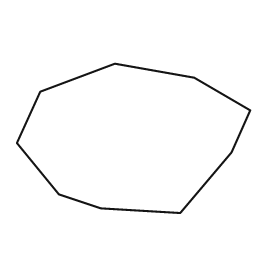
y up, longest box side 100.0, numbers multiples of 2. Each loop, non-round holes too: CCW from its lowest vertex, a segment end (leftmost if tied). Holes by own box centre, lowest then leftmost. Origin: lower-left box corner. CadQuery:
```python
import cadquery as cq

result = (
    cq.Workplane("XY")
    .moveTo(70.0, 0.0)
    .lineTo(92.0, 26.0)
    .lineTo(100.0, 44.0)
    .lineTo(76.0, 58.0)
    .lineTo(42.0, 64.0)
    .lineTo(10.0, 52.0)
    .lineTo(0.0, 30.0)
    .lineTo(18.0, 8.0)
    .lineTo(36.0, 2.0)
    .close()
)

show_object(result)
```